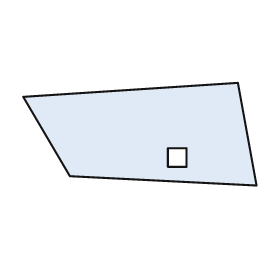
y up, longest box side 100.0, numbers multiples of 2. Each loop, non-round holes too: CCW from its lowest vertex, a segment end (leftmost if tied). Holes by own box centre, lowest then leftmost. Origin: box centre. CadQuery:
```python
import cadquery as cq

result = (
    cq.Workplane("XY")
    .moveTo(50.0, -22.0)
    .lineTo(42.0, 22.0)
    .lineTo(-50.0, 16.0)
    .lineTo(-30.0, -18.0)
    .close()
    .moveTo(12.0, -14.0)
    .lineTo(20.0, -14.0)
    .lineTo(20.0, -6.0)
    .lineTo(12.0, -6.0)
    .close()
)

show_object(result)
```